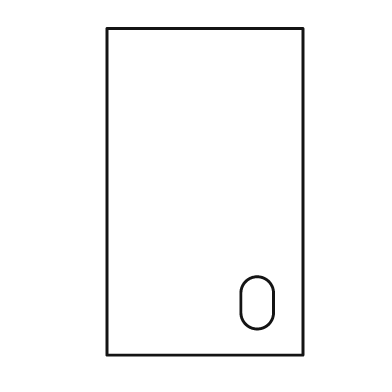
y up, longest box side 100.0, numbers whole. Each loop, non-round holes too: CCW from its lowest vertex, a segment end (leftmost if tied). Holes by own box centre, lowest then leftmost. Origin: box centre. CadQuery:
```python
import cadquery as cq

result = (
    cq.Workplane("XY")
    .moveTo(-30.0, -50.0)
    .lineTo(30.0, -50.0)
    .lineTo(30.0, 50.0)
    .lineTo(-30.0, 50.0)
    .close()
    .moveTo(11.0, -37.0)
    .threePointArc((16.0, -42.0), (21.0, -37.0))
    .lineTo(21.0, -31.0)
    .threePointArc((16.0, -26.0), (11.0, -31.0))
    .close()
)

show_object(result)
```